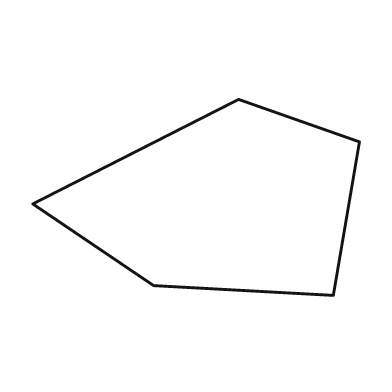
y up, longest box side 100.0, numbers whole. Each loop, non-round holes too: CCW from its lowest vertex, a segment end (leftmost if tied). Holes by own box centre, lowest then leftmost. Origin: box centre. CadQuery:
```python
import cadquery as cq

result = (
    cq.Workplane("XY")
    .moveTo(42.0, -30.0)
    .lineTo(50.0, 17.0)
    .lineTo(13.0, 30.0)
    .lineTo(-50.0, -2.0)
    .lineTo(-13.0, -27.0)
    .close()
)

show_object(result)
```